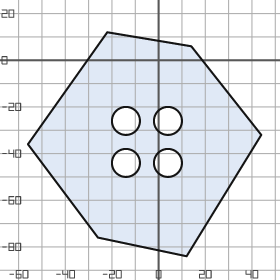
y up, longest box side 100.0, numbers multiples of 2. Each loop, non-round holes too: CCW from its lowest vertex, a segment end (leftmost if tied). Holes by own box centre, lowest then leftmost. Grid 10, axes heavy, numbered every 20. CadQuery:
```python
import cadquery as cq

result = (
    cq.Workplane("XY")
    .moveTo(12.0, -84.0)
    .lineTo(44.0, -32.0)
    .lineTo(14.0, 6.0)
    .lineTo(-22.0, 12.0)
    .lineTo(-56.0, -36.0)
    .lineTo(-26.0, -76.0)
    .close()
    .moveTo(-14.0, -44.0)
    .circle(6.0)
    .moveTo(4.0, -44.0)
    .circle(6.0)
    .moveTo(-14.0, -26.0)
    .circle(6.0)
    .moveTo(4.0, -26.0)
    .circle(6.0)
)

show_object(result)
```